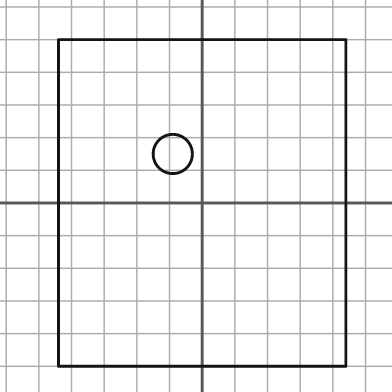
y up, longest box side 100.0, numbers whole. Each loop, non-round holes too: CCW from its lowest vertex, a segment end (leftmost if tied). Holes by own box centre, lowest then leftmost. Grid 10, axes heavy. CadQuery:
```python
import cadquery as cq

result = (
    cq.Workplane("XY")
    .moveTo(-44.0, -50.0)
    .lineTo(44.0, -50.0)
    .lineTo(44.0, 50.0)
    .lineTo(-44.0, 50.0)
    .close()
    .moveTo(-9.0, 15.0)
    .circle(6.0)
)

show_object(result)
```